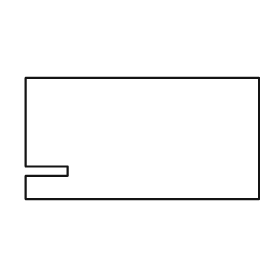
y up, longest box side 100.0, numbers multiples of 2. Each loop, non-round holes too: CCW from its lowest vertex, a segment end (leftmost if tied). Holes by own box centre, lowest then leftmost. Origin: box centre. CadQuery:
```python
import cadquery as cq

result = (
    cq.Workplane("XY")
    .moveTo(-50.0, -26.0)
    .lineTo(50.0, -26.0)
    .lineTo(50.0, 26.0)
    .lineTo(-50.0, 26.0)
    .lineTo(-50.0, -12.0)
    .lineTo(-32.0, -12.0)
    .lineTo(-32.0, -16.0)
    .lineTo(-50.0, -16.0)
    .close()
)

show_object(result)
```